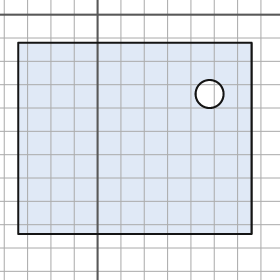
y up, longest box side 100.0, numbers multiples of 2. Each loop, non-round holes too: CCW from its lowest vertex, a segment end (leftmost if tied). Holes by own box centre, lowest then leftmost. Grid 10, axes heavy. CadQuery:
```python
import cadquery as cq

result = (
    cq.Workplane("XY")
    .moveTo(-34.0, -94.0)
    .lineTo(66.0, -94.0)
    .lineTo(66.0, -12.0)
    .lineTo(-34.0, -12.0)
    .close()
    .moveTo(48.0, -34.0)
    .circle(6.0)
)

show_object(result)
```